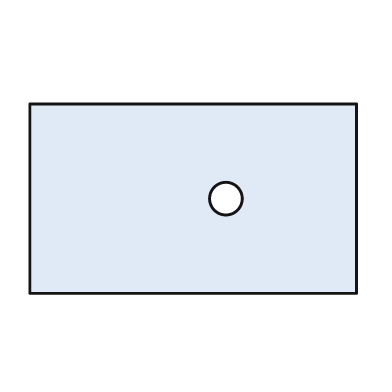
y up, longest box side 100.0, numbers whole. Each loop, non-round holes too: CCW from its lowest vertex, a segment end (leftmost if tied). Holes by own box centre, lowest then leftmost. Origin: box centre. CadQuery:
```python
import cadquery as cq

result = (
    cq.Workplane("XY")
    .moveTo(-50.0, -29.0)
    .lineTo(50.0, -29.0)
    .lineTo(50.0, 29.0)
    .lineTo(-50.0, 29.0)
    .close()
    .moveTo(10.0, 0.0)
    .circle(5.0)
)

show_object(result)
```